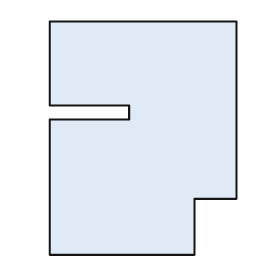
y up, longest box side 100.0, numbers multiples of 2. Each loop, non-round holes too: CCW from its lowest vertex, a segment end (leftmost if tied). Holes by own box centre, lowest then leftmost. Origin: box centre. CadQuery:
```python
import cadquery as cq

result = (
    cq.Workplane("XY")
    .moveTo(-40.0, -50.0)
    .lineTo(22.0, -50.0)
    .lineTo(22.0, -26.0)
    .lineTo(40.0, -26.0)
    .lineTo(40.0, 50.0)
    .lineTo(-40.0, 50.0)
    .lineTo(-40.0, 14.0)
    .lineTo(-6.0, 14.0)
    .lineTo(-6.0, 8.0)
    .lineTo(-40.0, 8.0)
    .close()
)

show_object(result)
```